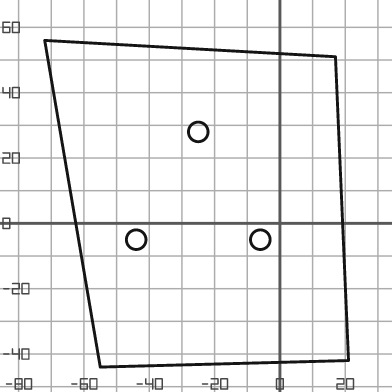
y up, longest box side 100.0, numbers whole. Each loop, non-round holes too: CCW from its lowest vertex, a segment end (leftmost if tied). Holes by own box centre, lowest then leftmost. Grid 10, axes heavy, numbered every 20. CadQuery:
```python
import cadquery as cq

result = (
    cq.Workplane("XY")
    .moveTo(-55.0, -44.0)
    .lineTo(21.0, -42.0)
    .lineTo(17.0, 51.0)
    .lineTo(-72.0, 56.0)
    .close()
    .moveTo(-44.0, -5.0)
    .circle(3.0)
    .moveTo(-6.0, -5.0)
    .circle(3.0)
    .moveTo(-25.0, 28.0)
    .circle(3.0)
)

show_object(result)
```